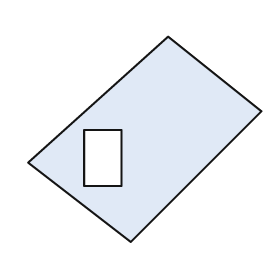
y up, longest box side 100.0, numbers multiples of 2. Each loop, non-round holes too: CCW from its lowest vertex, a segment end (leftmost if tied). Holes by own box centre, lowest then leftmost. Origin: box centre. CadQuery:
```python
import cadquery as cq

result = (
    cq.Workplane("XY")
    .moveTo(-6.0, -44.0)
    .lineTo(50.0, 12.0)
    .lineTo(10.0, 44.0)
    .lineTo(-50.0, -10.0)
    .close()
    .moveTo(-26.0, -20.0)
    .lineTo(-10.0, -20.0)
    .lineTo(-10.0, 4.0)
    .lineTo(-26.0, 4.0)
    .close()
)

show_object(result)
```